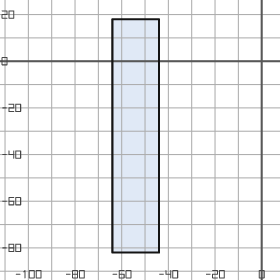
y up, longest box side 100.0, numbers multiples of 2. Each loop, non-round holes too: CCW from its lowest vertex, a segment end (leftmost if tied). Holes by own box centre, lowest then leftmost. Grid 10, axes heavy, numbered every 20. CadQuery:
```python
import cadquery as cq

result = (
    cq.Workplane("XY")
    .moveTo(-64.0, -82.0)
    .lineTo(-44.0, -82.0)
    .lineTo(-44.0, 18.0)
    .lineTo(-64.0, 18.0)
    .close()
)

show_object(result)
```